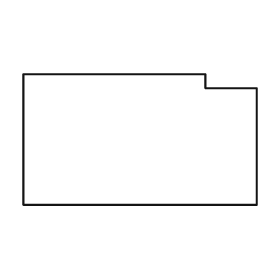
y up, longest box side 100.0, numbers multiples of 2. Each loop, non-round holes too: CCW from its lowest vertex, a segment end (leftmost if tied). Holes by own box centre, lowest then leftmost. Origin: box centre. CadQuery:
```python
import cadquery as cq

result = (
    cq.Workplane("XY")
    .moveTo(-50.0, -28.0)
    .lineTo(50.0, -28.0)
    .lineTo(50.0, 22.0)
    .lineTo(28.0, 22.0)
    .lineTo(28.0, 28.0)
    .lineTo(-50.0, 28.0)
    .close()
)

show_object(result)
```